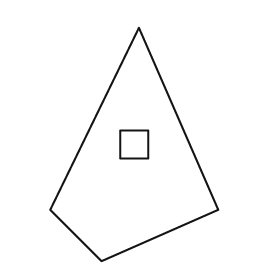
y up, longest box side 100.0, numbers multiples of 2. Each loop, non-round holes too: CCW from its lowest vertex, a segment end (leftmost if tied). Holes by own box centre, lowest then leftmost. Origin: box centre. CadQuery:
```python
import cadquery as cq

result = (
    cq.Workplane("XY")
    .moveTo(-14.0, -50.0)
    .lineTo(36.0, -28.0)
    .lineTo(2.0, 50.0)
    .lineTo(-36.0, -28.0)
    .close()
    .moveTo(-6.0, -6.0)
    .lineTo(6.0, -6.0)
    .lineTo(6.0, 6.0)
    .lineTo(-6.0, 6.0)
    .close()
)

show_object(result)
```